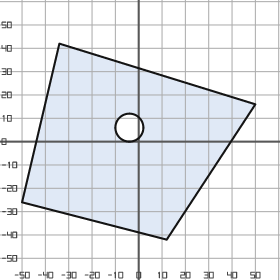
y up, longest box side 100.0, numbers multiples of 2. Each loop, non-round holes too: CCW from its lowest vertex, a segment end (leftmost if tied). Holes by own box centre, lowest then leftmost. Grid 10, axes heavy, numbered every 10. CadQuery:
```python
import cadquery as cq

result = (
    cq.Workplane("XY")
    .moveTo(12.0, -42.0)
    .lineTo(50.0, 16.0)
    .lineTo(-34.0, 42.0)
    .lineTo(-50.0, -26.0)
    .close()
    .moveTo(-4.0, 6.0)
    .circle(6.0)
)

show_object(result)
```